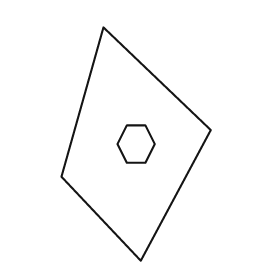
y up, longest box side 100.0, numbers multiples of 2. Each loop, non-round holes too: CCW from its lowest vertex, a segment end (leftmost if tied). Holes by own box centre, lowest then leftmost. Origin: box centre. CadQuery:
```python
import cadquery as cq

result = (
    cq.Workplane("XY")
    .moveTo(2.0, -50.0)
    .lineTo(32.0, 6.0)
    .lineTo(-14.0, 50.0)
    .lineTo(-32.0, -14.0)
    .close()
    .moveTo(-4.0, -8.0)
    .lineTo(4.0, -8.0)
    .lineTo(8.0, 0.0)
    .lineTo(4.0, 8.0)
    .lineTo(-4.0, 8.0)
    .lineTo(-8.0, 0.0)
    .close()
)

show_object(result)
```